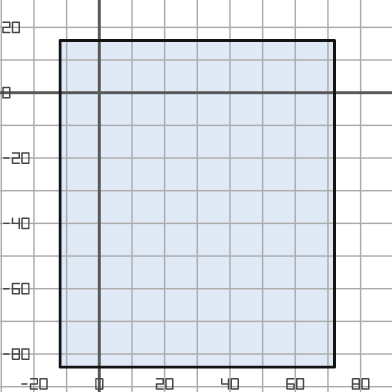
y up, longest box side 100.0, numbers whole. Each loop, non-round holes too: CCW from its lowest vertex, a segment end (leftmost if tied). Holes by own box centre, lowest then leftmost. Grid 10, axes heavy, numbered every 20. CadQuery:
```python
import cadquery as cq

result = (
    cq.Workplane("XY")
    .moveTo(-12.0, -84.0)
    .lineTo(72.0, -84.0)
    .lineTo(72.0, 16.0)
    .lineTo(-12.0, 16.0)
    .close()
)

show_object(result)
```